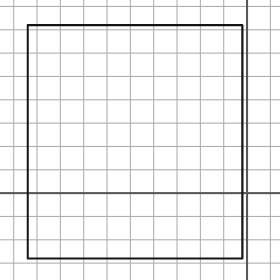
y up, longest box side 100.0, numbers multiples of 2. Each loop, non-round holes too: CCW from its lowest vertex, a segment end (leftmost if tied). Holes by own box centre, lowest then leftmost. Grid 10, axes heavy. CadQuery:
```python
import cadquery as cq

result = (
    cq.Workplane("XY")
    .moveTo(-94.0, -28.0)
    .lineTo(-2.0, -28.0)
    .lineTo(-2.0, 72.0)
    .lineTo(-94.0, 72.0)
    .close()
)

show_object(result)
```